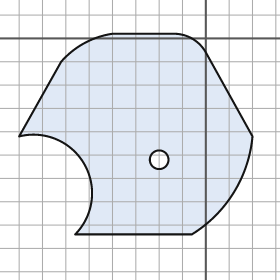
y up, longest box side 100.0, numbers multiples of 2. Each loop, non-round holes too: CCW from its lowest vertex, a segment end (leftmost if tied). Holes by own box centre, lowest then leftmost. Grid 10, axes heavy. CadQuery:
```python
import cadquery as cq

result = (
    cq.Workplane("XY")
    .moveTo(-56.0, -84.0)
    .lineTo(-6.0, -84.0)
    .threePointArc((12.0, -66.0), (20.0, -42.0))
    .lineTo(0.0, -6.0)
    .threePointArc((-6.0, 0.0), (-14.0, 2.0))
    .lineTo(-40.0, 2.0)
    .threePointArc((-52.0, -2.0), (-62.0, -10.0))
    .lineTo(-80.0, -42.0)
    .threePointArc((-52.0, -54.0), (-56.0, -84.0))
    .close()
    .moveTo(-20.0, -52.0)
    .circle(4.0)
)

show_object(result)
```